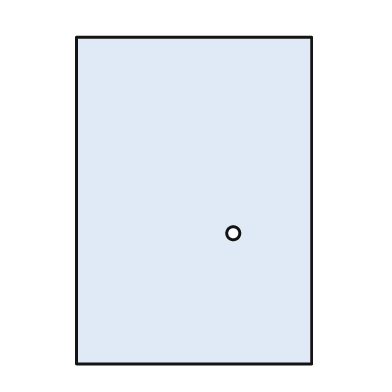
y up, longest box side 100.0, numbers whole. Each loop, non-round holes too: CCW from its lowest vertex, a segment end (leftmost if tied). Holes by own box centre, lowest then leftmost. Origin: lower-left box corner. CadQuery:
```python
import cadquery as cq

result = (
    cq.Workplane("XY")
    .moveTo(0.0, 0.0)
    .lineTo(72.0, 0.0)
    .lineTo(72.0, 100.0)
    .lineTo(0.0, 100.0)
    .close()
    .moveTo(48.0, 40.0)
    .circle(2.0)
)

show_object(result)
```